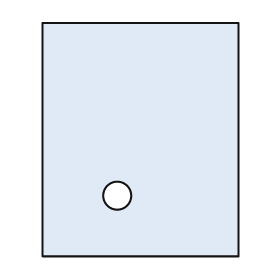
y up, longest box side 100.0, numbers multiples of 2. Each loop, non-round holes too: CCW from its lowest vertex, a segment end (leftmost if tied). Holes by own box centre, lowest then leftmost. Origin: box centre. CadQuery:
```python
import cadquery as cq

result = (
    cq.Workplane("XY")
    .moveTo(-42.0, -50.0)
    .lineTo(42.0, -50.0)
    .lineTo(42.0, 50.0)
    .lineTo(-42.0, 50.0)
    .close()
    .moveTo(-10.0, -24.0)
    .circle(6.0)
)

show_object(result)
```